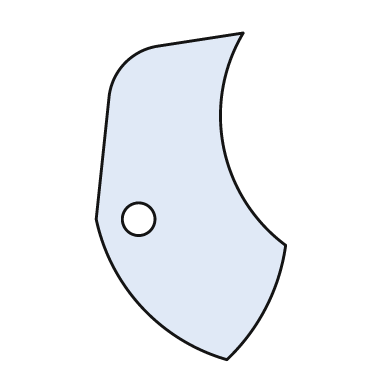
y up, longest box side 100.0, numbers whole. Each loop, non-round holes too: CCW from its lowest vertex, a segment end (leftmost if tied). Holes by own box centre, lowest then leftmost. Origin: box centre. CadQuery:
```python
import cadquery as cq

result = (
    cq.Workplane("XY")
    .moveTo(11.0, -50.0)
    .threePointArc((23.0, -34.0), (29.0, -15.0))
    .threePointArc((10.0, 15.0), (16.0, 50.0))
    .lineTo(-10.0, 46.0)
    .threePointArc((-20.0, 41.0), (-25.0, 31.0))
    .lineTo(-29.0, -7.0)
    .threePointArc((-15.0, -34.0), (11.0, -50.0))
    .close()
    .moveTo(-16.0, -7.0)
    .circle(5.0)
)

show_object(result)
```